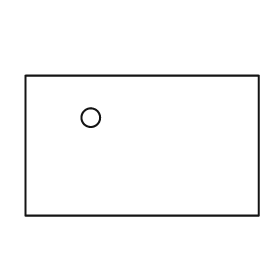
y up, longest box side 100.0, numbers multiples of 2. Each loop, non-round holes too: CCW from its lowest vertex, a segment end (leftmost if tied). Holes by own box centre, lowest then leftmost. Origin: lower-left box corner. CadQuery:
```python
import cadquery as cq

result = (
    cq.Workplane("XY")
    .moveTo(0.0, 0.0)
    .lineTo(100.0, 0.0)
    .lineTo(100.0, 60.0)
    .lineTo(0.0, 60.0)
    .close()
    .moveTo(28.0, 42.0)
    .circle(4.0)
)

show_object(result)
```